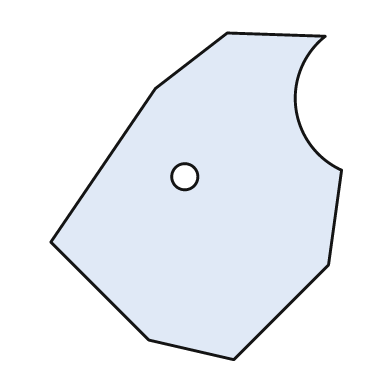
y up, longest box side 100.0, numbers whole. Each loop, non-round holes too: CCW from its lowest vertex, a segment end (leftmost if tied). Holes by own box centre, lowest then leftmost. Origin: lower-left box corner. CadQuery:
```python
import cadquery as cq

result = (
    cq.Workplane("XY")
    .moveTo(56.0, 0.0)
    .lineTo(85.0, 29.0)
    .lineTo(89.0, 58.0)
    .threePointArc((75.0, 77.0), (84.0, 99.0))
    .lineTo(54.0, 100.0)
    .lineTo(32.0, 83.0)
    .lineTo(0.0, 36.0)
    .lineTo(30.0, 6.0)
    .close()
    .moveTo(41.0, 56.0)
    .circle(4.0)
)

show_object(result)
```